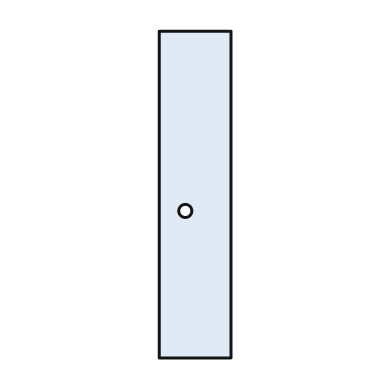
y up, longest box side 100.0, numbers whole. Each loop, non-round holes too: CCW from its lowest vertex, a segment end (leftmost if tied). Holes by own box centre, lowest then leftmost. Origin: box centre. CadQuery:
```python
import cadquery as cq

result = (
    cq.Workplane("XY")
    .moveTo(-11.0, -50.0)
    .lineTo(11.0, -50.0)
    .lineTo(11.0, 50.0)
    .lineTo(-11.0, 50.0)
    .close()
    .moveTo(-3.0, -5.0)
    .circle(2.0)
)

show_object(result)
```